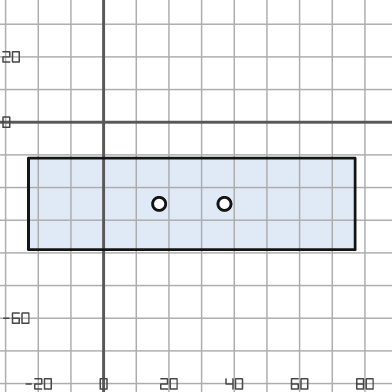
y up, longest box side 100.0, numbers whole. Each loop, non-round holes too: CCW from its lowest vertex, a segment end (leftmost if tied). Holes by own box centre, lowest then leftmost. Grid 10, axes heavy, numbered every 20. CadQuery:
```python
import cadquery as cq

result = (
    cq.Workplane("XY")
    .moveTo(-23.0, -39.0)
    .lineTo(77.0, -39.0)
    .lineTo(77.0, -11.0)
    .lineTo(-23.0, -11.0)
    .close()
    .moveTo(17.0, -25.0)
    .circle(2.0)
    .moveTo(37.0, -25.0)
    .circle(2.0)
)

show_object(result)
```